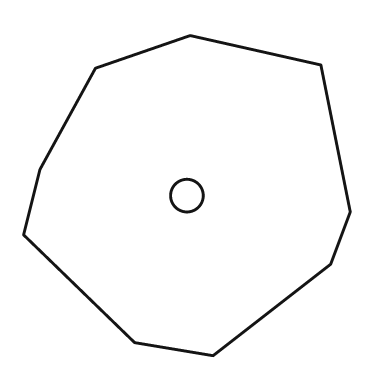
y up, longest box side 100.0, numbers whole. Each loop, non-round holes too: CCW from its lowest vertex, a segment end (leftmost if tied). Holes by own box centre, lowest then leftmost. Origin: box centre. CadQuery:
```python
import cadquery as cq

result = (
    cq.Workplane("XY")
    .moveTo(8.0, -49.0)
    .lineTo(44.0, -21.0)
    .lineTo(50.0, -5.0)
    .lineTo(41.0, 40.0)
    .lineTo(1.0, 49.0)
    .lineTo(-28.0, 39.0)
    .lineTo(-45.0, 8.0)
    .lineTo(-50.0, -12.0)
    .lineTo(-16.0, -45.0)
    .close()
    .moveTo(0.0, 0.0)
    .circle(5.0)
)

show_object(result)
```